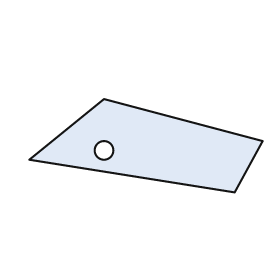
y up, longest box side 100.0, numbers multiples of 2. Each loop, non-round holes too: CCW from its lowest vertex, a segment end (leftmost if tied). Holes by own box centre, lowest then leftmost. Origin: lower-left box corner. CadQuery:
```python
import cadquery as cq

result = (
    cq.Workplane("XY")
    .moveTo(88.0, 0.0)
    .lineTo(100.0, 22.0)
    .lineTo(32.0, 40.0)
    .lineTo(0.0, 14.0)
    .close()
    .moveTo(32.0, 18.0)
    .circle(4.0)
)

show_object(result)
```